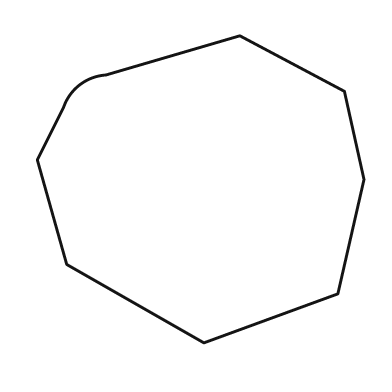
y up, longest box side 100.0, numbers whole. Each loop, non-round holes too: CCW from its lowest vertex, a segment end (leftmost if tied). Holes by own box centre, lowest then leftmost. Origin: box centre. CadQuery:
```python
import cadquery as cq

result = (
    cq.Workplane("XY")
    .moveTo(1.0, -47.0)
    .lineTo(42.0, -32.0)
    .lineTo(50.0, 3.0)
    .lineTo(44.0, 30.0)
    .lineTo(12.0, 47.0)
    .lineTo(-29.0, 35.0)
    .threePointArc((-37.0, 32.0), (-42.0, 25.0))
    .lineTo(-50.0, 9.0)
    .lineTo(-41.0, -23.0)
    .close()
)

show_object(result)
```